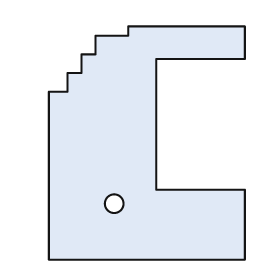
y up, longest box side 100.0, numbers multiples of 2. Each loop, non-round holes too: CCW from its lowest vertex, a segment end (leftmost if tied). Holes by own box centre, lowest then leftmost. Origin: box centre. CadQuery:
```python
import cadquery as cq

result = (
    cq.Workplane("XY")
    .moveTo(-42.0, -50.0)
    .lineTo(42.0, -50.0)
    .lineTo(42.0, -20.0)
    .lineTo(4.0, -20.0)
    .lineTo(4.0, 36.0)
    .lineTo(42.0, 36.0)
    .lineTo(42.0, 50.0)
    .lineTo(-8.0, 50.0)
    .lineTo(-8.0, 46.0)
    .lineTo(-22.0, 46.0)
    .lineTo(-22.0, 38.0)
    .lineTo(-28.0, 38.0)
    .lineTo(-28.0, 30.0)
    .lineTo(-34.0, 30.0)
    .lineTo(-34.0, 22.0)
    .lineTo(-42.0, 22.0)
    .close()
    .moveTo(-14.0, -26.0)
    .circle(4.0)
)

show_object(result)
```